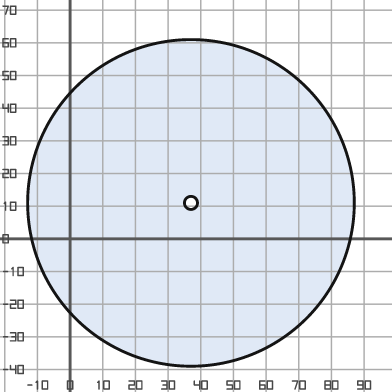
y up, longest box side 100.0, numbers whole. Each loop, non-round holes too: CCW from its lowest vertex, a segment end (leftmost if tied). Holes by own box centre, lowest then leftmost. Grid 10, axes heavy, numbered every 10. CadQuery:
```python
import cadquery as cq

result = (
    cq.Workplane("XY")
    .moveTo(37.0, 11.0)
    .circle(50.0)
    .moveTo(37.0, 11.0)
    .circle(2.0)
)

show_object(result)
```